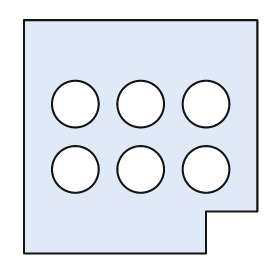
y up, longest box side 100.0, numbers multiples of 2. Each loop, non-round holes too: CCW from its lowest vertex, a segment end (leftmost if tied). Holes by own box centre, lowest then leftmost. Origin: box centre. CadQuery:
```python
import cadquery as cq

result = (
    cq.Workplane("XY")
    .moveTo(-50.0, -50.0)
    .lineTo(28.0, -50.0)
    .lineTo(28.0, -32.0)
    .lineTo(50.0, -32.0)
    .lineTo(50.0, 50.0)
    .lineTo(-50.0, 50.0)
    .close()
    .moveTo(-28.0, -14.0)
    .circle(10.0)
    .moveTo(0.0, -14.0)
    .circle(10.0)
    .moveTo(28.0, -14.0)
    .circle(10.0)
    .moveTo(-28.0, 14.0)
    .circle(10.0)
    .moveTo(0.0, 14.0)
    .circle(10.0)
    .moveTo(28.0, 14.0)
    .circle(10.0)
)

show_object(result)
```